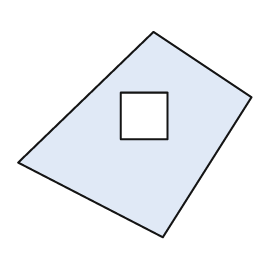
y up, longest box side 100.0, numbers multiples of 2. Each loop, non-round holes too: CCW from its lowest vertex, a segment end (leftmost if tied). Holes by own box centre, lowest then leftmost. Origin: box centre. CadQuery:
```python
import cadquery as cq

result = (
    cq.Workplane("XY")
    .moveTo(12.0, -44.0)
    .lineTo(50.0, 16.0)
    .lineTo(8.0, 44.0)
    .lineTo(-50.0, -12.0)
    .close()
    .moveTo(-6.0, -2.0)
    .lineTo(14.0, -2.0)
    .lineTo(14.0, 18.0)
    .lineTo(-6.0, 18.0)
    .close()
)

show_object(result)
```